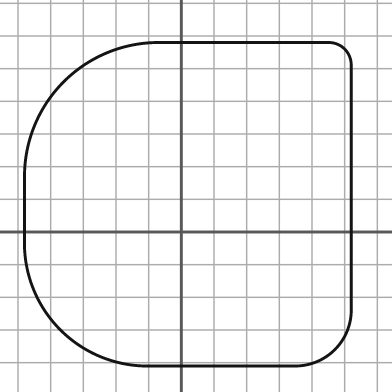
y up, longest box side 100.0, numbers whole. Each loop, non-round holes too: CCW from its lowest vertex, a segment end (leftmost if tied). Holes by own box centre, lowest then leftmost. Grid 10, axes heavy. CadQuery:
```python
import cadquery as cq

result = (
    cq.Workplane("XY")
    .moveTo(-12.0, -41.0)
    .lineTo(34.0, -41.0)
    .threePointArc((47.0, -36.0), (52.0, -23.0))
    .lineTo(52.0, 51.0)
    .threePointArc((50.0, 56.0), (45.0, 58.0))
    .lineTo(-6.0, 58.0)
    .threePointArc((-36.0, 46.0), (-48.0, 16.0))
    .lineTo(-48.0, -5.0)
    .threePointArc((-37.0, -30.0), (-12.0, -41.0))
    .close()
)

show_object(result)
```